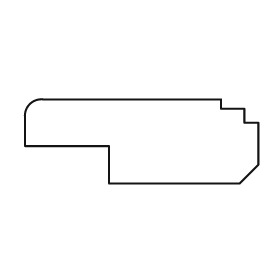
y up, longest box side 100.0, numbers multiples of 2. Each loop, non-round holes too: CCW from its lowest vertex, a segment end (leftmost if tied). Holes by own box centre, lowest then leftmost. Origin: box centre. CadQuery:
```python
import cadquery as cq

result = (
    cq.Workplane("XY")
    .moveTo(-14.0, -18.0)
    .lineTo(42.0, -18.0)
    .lineTo(50.0, -10.0)
    .lineTo(50.0, 8.0)
    .lineTo(44.0, 8.0)
    .lineTo(44.0, 14.0)
    .lineTo(34.0, 14.0)
    .lineTo(34.0, 18.0)
    .lineTo(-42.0, 18.0)
    .threePointArc((-48.0, 16.0), (-50.0, 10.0))
    .lineTo(-50.0, -2.0)
    .lineTo(-14.0, -2.0)
    .close()
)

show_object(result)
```